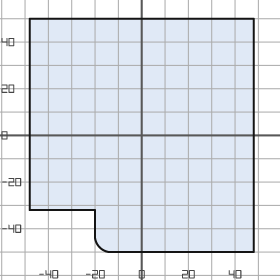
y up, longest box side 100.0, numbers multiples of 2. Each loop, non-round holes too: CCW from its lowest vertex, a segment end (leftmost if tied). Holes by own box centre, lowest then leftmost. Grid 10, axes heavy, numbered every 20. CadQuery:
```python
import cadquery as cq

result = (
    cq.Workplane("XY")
    .moveTo(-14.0, -50.0)
    .lineTo(48.0, -50.0)
    .lineTo(48.0, 50.0)
    .lineTo(-48.0, 50.0)
    .lineTo(-48.0, -32.0)
    .lineTo(-20.0, -32.0)
    .lineTo(-20.0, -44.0)
    .threePointArc((-18.0, -48.0), (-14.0, -50.0))
    .close()
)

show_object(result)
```